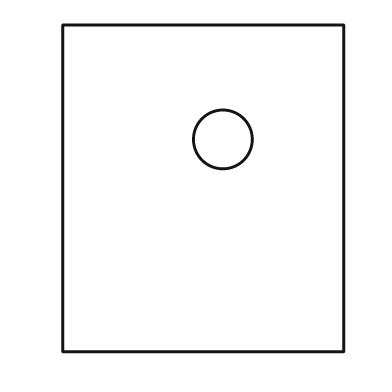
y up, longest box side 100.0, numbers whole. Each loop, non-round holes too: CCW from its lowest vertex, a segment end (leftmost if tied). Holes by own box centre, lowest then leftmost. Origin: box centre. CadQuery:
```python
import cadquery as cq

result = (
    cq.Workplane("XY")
    .moveTo(-43.0, -50.0)
    .lineTo(43.0, -50.0)
    .lineTo(43.0, 50.0)
    .lineTo(-43.0, 50.0)
    .close()
    .moveTo(6.0, 15.0)
    .circle(9.0)
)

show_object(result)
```